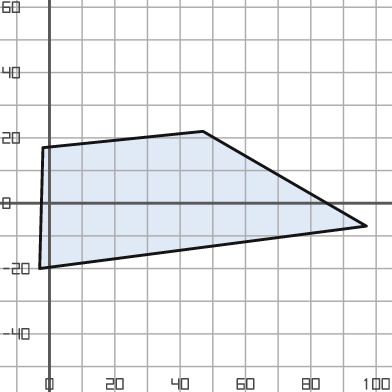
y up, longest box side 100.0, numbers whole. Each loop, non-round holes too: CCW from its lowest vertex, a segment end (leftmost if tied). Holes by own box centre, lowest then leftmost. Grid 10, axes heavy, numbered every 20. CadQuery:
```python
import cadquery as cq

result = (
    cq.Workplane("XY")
    .moveTo(-3.0, -20.0)
    .lineTo(97.0, -7.0)
    .lineTo(47.0, 22.0)
    .lineTo(-2.0, 17.0)
    .close()
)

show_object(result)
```